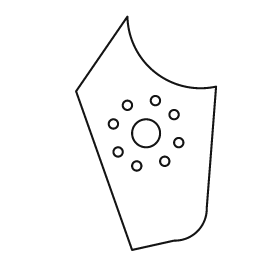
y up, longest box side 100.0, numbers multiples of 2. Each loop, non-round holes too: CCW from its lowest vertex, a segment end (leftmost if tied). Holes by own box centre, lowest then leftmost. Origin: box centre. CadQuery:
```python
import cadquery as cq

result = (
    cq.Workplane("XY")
    .moveTo(-6.0, -50.0)
    .lineTo(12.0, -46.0)
    .threePointArc((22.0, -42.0), (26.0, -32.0))
    .lineTo(30.0, 20.0)
    .threePointArc((4.0, 26.0), (-8.0, 50.0))
    .lineTo(-30.0, 18.0)
    .close()
    .moveTo(-4.0, -14.0)
    .circle(2.0)
    .moveTo(8.0, -12.0)
    .circle(2.0)
    .moveTo(-12.0, -8.0)
    .circle(2.0)
    .moveTo(14.0, -4.0)
    .circle(2.0)
    .moveTo(0.0, 0.0)
    .circle(6.0)
    .moveTo(-14.0, 4.0)
    .circle(2.0)
    .moveTo(12.0, 8.0)
    .circle(2.0)
    .moveTo(-8.0, 12.0)
    .circle(2.0)
    .moveTo(4.0, 14.0)
    .circle(2.0)
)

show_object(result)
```